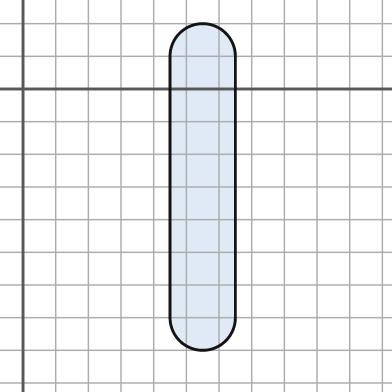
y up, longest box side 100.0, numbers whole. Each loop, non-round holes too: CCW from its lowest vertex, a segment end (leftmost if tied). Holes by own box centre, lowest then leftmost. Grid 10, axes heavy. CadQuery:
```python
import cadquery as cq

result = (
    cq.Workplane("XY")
    .moveTo(45.0, -70.0)
    .threePointArc((55.0, -80.0), (65.0, -70.0))
    .lineTo(65.0, 10.0)
    .threePointArc((55.0, 20.0), (45.0, 10.0))
    .close()
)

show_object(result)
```